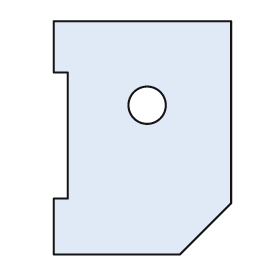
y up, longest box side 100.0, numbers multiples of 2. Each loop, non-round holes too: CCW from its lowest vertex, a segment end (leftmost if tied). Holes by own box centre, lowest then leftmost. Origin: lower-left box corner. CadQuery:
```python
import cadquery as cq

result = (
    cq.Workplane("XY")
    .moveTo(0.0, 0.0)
    .lineTo(54.0, 0.0)
    .lineTo(76.0, 22.0)
    .lineTo(76.0, 100.0)
    .lineTo(0.0, 100.0)
    .lineTo(0.0, 78.0)
    .lineTo(6.0, 78.0)
    .lineTo(6.0, 24.0)
    .lineTo(0.0, 24.0)
    .close()
    .moveTo(40.0, 64.0)
    .circle(8.0)
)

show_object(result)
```